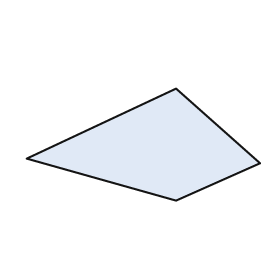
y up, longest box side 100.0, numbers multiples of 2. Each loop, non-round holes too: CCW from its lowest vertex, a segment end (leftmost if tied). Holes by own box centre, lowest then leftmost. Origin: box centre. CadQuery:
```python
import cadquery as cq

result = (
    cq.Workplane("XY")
    .moveTo(14.0, -24.0)
    .lineTo(50.0, -8.0)
    .lineTo(14.0, 24.0)
    .lineTo(-50.0, -6.0)
    .close()
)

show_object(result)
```